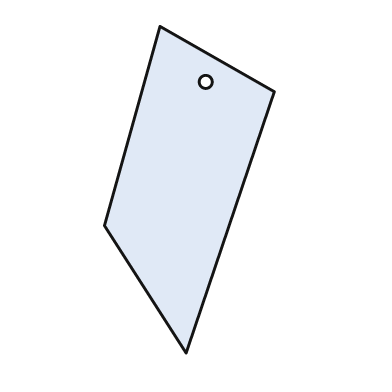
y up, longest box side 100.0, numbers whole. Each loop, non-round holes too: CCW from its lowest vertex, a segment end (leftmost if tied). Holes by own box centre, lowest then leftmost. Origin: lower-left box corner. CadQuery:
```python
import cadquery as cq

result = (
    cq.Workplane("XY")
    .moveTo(25.0, 0.0)
    .lineTo(52.0, 80.0)
    .lineTo(17.0, 100.0)
    .lineTo(0.0, 39.0)
    .close()
    .moveTo(31.0, 83.0)
    .circle(2.0)
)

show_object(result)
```